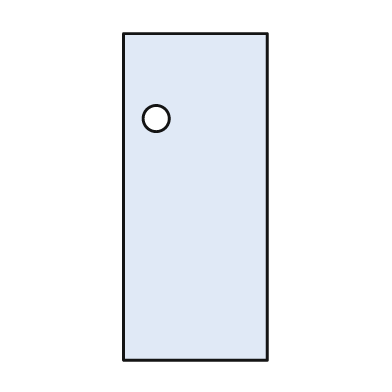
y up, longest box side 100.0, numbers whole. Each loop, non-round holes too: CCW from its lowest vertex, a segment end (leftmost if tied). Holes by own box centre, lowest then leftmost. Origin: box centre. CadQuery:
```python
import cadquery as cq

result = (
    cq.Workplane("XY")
    .moveTo(-22.0, -50.0)
    .lineTo(22.0, -50.0)
    .lineTo(22.0, 50.0)
    .lineTo(-22.0, 50.0)
    .close()
    .moveTo(-12.0, 24.0)
    .circle(4.0)
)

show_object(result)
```